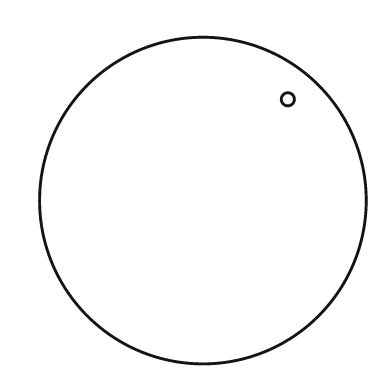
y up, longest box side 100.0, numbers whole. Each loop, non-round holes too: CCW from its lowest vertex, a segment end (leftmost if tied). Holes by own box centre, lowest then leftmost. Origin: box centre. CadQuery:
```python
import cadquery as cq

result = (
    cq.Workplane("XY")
    .moveTo(0.0, 0.0)
    .circle(50.0)
    .moveTo(26.0, 31.0)
    .circle(2.0)
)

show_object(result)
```